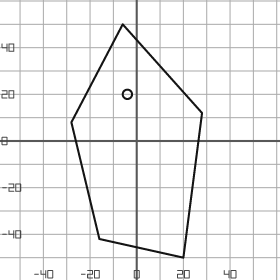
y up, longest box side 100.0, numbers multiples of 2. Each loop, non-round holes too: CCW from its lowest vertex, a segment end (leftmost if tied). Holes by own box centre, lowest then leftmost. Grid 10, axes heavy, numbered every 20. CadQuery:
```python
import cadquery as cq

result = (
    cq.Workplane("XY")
    .moveTo(20.0, -50.0)
    .lineTo(28.0, 12.0)
    .lineTo(-6.0, 50.0)
    .lineTo(-28.0, 8.0)
    .lineTo(-16.0, -42.0)
    .close()
    .moveTo(-4.0, 20.0)
    .circle(2.0)
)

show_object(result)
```